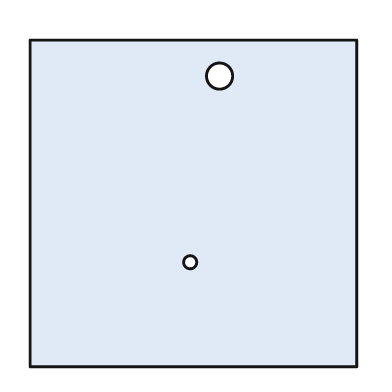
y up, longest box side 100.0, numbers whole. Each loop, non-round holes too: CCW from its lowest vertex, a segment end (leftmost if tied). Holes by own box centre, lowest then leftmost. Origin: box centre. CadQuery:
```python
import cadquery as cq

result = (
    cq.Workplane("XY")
    .moveTo(-50.0, -50.0)
    .lineTo(50.0, -50.0)
    .lineTo(50.0, 50.0)
    .lineTo(-50.0, 50.0)
    .close()
    .moveTo(-1.0, -18.0)
    .circle(2.0)
    .moveTo(8.0, 39.0)
    .circle(4.0)
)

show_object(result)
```